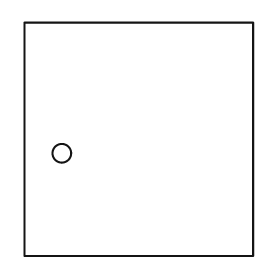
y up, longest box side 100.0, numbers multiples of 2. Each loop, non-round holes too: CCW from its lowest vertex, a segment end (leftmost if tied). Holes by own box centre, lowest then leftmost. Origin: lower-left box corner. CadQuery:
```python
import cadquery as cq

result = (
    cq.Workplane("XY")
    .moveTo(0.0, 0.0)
    .lineTo(98.0, 0.0)
    .lineTo(98.0, 100.0)
    .lineTo(0.0, 100.0)
    .close()
    .moveTo(16.0, 44.0)
    .circle(4.0)
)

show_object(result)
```